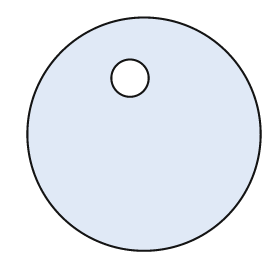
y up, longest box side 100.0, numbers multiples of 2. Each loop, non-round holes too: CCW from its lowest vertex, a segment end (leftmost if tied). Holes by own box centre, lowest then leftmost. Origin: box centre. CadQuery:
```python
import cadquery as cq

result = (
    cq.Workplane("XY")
    .moveTo(0.0, 0.0)
    .circle(50.0)
    .moveTo(-6.0, 24.0)
    .circle(8.0)
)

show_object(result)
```